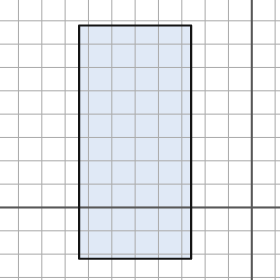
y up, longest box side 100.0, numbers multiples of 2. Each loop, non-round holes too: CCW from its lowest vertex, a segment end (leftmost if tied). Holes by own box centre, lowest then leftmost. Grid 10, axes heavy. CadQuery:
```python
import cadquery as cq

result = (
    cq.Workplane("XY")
    .moveTo(-74.0, -22.0)
    .lineTo(-26.0, -22.0)
    .lineTo(-26.0, 78.0)
    .lineTo(-74.0, 78.0)
    .close()
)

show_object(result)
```